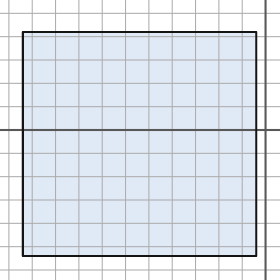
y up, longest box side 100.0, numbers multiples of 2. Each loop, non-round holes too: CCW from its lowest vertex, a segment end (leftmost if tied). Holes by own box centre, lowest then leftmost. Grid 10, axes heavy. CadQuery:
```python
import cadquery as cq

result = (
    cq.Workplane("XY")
    .moveTo(-104.0, -54.0)
    .lineTo(-4.0, -54.0)
    .lineTo(-4.0, 42.0)
    .lineTo(-104.0, 42.0)
    .close()
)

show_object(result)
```